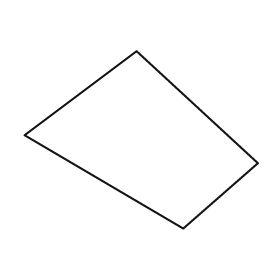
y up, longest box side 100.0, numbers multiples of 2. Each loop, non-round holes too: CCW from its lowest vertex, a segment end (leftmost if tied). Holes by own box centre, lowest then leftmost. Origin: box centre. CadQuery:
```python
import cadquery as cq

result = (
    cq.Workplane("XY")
    .moveTo(18.0, -38.0)
    .lineTo(50.0, -10.0)
    .lineTo(-2.0, 38.0)
    .lineTo(-50.0, 2.0)
    .close()
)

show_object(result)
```